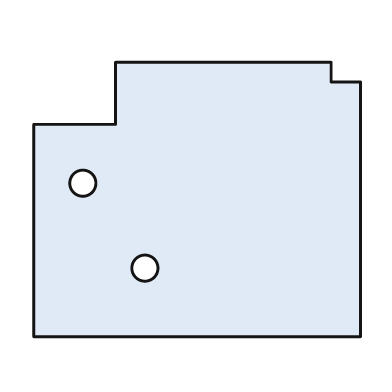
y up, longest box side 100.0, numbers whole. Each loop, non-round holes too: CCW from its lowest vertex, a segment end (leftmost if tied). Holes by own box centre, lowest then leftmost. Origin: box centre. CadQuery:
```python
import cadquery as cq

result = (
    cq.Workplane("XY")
    .moveTo(-50.0, -42.0)
    .lineTo(50.0, -42.0)
    .lineTo(50.0, 36.0)
    .lineTo(41.0, 36.0)
    .lineTo(41.0, 42.0)
    .lineTo(-25.0, 42.0)
    .lineTo(-25.0, 23.0)
    .lineTo(-50.0, 23.0)
    .close()
    .moveTo(-16.0, -21.0)
    .circle(4.0)
    .moveTo(-35.0, 5.0)
    .circle(4.0)
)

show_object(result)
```